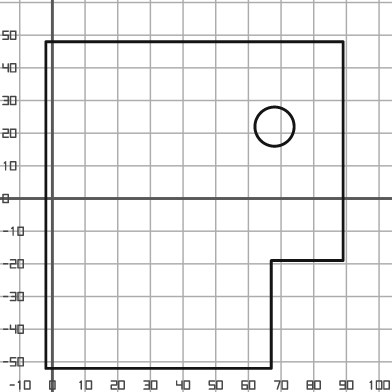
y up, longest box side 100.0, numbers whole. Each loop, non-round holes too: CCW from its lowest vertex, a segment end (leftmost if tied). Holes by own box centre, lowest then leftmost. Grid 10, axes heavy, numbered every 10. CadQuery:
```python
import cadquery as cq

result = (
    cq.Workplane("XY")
    .moveTo(-2.0, -52.0)
    .lineTo(67.0, -52.0)
    .lineTo(67.0, -19.0)
    .lineTo(89.0, -19.0)
    .lineTo(89.0, 48.0)
    .lineTo(-2.0, 48.0)
    .close()
    .moveTo(68.0, 22.0)
    .circle(6.0)
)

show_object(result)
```